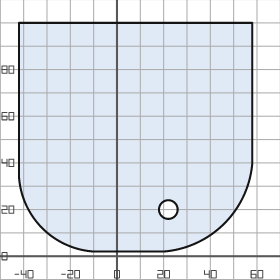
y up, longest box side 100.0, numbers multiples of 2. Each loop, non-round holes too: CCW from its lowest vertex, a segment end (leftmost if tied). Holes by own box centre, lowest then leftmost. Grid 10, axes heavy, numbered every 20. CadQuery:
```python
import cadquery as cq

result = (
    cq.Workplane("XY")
    .moveTo(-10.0, 2.0)
    .lineTo(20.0, 2.0)
    .threePointArc((46.0, 14.0), (58.0, 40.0))
    .lineTo(58.0, 100.0)
    .lineTo(-42.0, 100.0)
    .lineTo(-42.0, 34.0)
    .threePointArc((-32.0, 12.0), (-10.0, 2.0))
    .close()
    .moveTo(22.0, 20.0)
    .circle(4.0)
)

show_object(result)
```